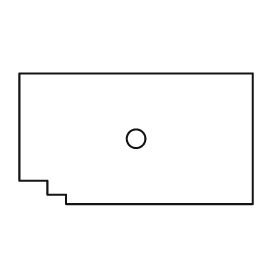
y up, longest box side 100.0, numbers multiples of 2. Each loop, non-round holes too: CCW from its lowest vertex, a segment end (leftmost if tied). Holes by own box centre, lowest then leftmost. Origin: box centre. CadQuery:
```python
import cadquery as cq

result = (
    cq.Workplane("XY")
    .moveTo(-30.0, -28.0)
    .lineTo(50.0, -28.0)
    .lineTo(50.0, 28.0)
    .lineTo(-50.0, 28.0)
    .lineTo(-50.0, -18.0)
    .lineTo(-38.0, -18.0)
    .lineTo(-38.0, -24.0)
    .lineTo(-30.0, -24.0)
    .close()
    .moveTo(0.0, 0.0)
    .circle(4.0)
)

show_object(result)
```